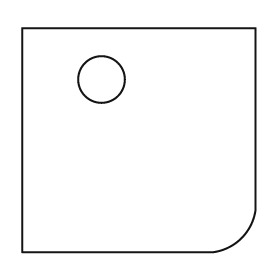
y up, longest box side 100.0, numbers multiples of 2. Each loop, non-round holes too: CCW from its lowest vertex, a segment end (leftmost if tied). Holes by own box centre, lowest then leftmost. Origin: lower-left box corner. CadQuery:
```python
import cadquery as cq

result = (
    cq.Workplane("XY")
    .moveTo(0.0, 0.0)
    .lineTo(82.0, 0.0)
    .threePointArc((94.0, 6.0), (100.0, 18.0))
    .lineTo(100.0, 96.0)
    .lineTo(0.0, 96.0)
    .close()
    .moveTo(34.0, 74.0)
    .circle(10.0)
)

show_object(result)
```